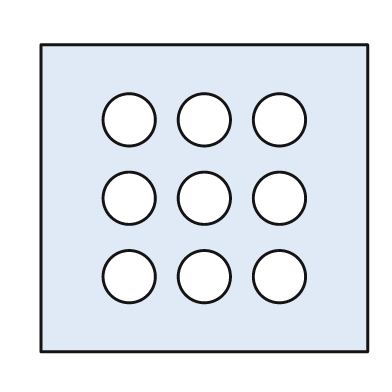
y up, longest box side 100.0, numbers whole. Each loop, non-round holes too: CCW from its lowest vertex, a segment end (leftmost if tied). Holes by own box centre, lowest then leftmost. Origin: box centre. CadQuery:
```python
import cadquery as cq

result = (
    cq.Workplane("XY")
    .moveTo(-50.0, -47.0)
    .lineTo(50.0, -47.0)
    .lineTo(50.0, 47.0)
    .lineTo(-50.0, 47.0)
    .close()
    .moveTo(-23.0, -24.0)
    .circle(8.0)
    .moveTo(0.0, -24.0)
    .circle(8.0)
    .moveTo(23.0, -24.0)
    .circle(8.0)
    .moveTo(-23.0, 0.0)
    .circle(8.0)
    .moveTo(0.0, 0.0)
    .circle(8.0)
    .moveTo(23.0, 0.0)
    .circle(8.0)
    .moveTo(-23.0, 24.0)
    .circle(8.0)
    .moveTo(0.0, 24.0)
    .circle(8.0)
    .moveTo(23.0, 24.0)
    .circle(8.0)
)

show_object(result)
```